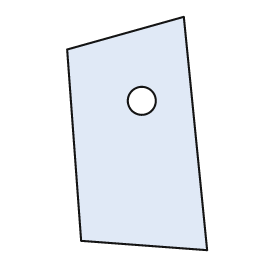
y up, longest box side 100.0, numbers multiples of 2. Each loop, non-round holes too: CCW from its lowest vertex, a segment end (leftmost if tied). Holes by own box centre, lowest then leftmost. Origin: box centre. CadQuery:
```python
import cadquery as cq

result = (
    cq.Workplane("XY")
    .moveTo(30.0, -50.0)
    .lineTo(20.0, 50.0)
    .lineTo(-30.0, 36.0)
    .lineTo(-24.0, -46.0)
    .close()
    .moveTo(2.0, 14.0)
    .circle(6.0)
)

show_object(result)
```